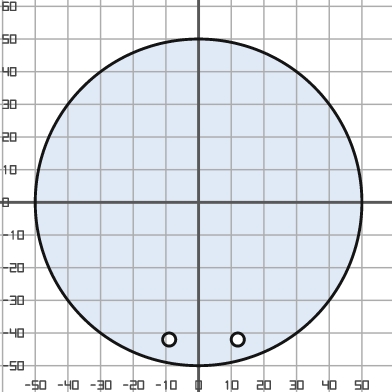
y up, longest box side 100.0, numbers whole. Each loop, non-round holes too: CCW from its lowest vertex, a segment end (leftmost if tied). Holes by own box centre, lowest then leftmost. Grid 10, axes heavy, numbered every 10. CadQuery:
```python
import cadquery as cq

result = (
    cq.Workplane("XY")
    .moveTo(0.0, 0.0)
    .circle(50.0)
    .moveTo(-9.0, -42.0)
    .circle(2.0)
    .moveTo(12.0, -42.0)
    .circle(2.0)
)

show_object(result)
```